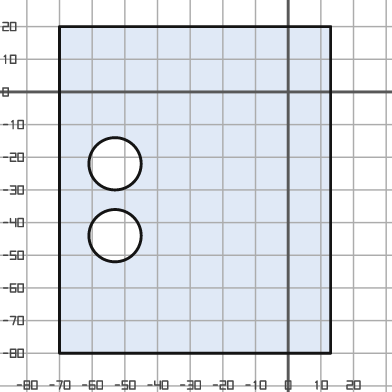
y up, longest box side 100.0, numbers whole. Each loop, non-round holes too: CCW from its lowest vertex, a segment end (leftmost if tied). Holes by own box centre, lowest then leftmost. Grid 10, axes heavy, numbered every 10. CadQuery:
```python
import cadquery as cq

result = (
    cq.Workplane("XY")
    .moveTo(-70.0, -80.0)
    .lineTo(13.0, -80.0)
    .lineTo(13.0, 20.0)
    .lineTo(-70.0, 20.0)
    .close()
    .moveTo(-53.0, -44.0)
    .circle(8.0)
    .moveTo(-53.0, -22.0)
    .circle(8.0)
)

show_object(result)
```